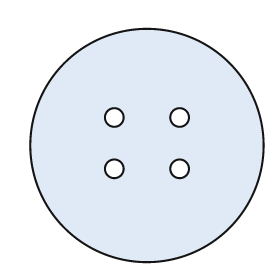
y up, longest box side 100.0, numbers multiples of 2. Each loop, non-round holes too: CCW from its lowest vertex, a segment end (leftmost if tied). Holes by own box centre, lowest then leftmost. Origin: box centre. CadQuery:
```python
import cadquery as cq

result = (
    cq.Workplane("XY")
    .moveTo(0.0, 0.0)
    .circle(50.0)
    .moveTo(-14.0, -10.0)
    .circle(4.0)
    .moveTo(14.0, -10.0)
    .circle(4.0)
    .moveTo(-14.0, 12.0)
    .circle(4.0)
    .moveTo(14.0, 12.0)
    .circle(4.0)
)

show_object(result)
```